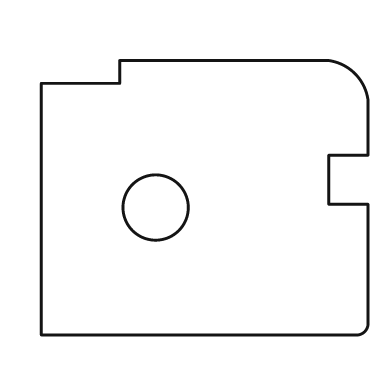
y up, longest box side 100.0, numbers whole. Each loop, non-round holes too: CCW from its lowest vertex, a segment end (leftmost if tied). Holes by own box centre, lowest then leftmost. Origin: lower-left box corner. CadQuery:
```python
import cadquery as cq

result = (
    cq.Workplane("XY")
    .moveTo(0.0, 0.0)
    .lineTo(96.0, 0.0)
    .threePointArc((99.0, 1.0), (100.0, 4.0))
    .lineTo(100.0, 40.0)
    .lineTo(88.0, 40.0)
    .lineTo(88.0, 55.0)
    .lineTo(100.0, 55.0)
    .lineTo(100.0, 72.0)
    .threePointArc((96.0, 80.0), (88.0, 84.0))
    .lineTo(24.0, 84.0)
    .lineTo(24.0, 77.0)
    .lineTo(0.0, 77.0)
    .close()
    .moveTo(35.0, 39.0)
    .circle(10.0)
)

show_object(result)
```